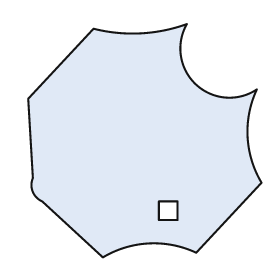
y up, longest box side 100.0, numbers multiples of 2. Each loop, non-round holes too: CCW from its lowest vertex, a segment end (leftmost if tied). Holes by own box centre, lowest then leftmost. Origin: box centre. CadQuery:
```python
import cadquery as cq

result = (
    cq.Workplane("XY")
    .moveTo(-18.0, -50.0)
    .threePointArc((2.0, -44.0), (22.0, -48.0))
    .lineTo(50.0, -18.0)
    .threePointArc((44.0, 2.0), (48.0, 22.0))
    .threePointArc((22.0, 24.0), (18.0, 50.0))
    .threePointArc((-2.0, 46.0), (-22.0, 48.0))
    .lineTo(-50.0, 18.0)
    .lineTo(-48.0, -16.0)
    .threePointArc((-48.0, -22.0), (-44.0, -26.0))
    .close()
    .moveTo(6.0, -34.0)
    .lineTo(14.0, -34.0)
    .lineTo(14.0, -26.0)
    .lineTo(6.0, -26.0)
    .close()
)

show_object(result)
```